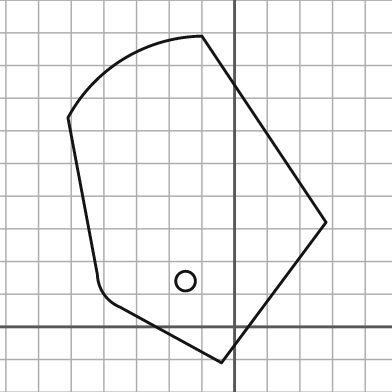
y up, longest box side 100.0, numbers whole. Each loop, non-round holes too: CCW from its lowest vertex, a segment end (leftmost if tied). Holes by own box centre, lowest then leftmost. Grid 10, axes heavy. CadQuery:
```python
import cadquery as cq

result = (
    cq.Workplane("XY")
    .moveTo(-4.0, -11.0)
    .lineTo(28.0, 32.0)
    .lineTo(-10.0, 89.0)
    .threePointArc((-34.0, 82.0), (-51.0, 64.0))
    .lineTo(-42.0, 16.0)
    .threePointArc((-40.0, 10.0), (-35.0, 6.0))
    .close()
    .moveTo(-15.0, 14.0)
    .circle(3.0)
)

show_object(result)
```